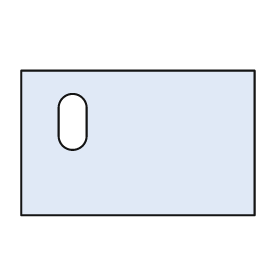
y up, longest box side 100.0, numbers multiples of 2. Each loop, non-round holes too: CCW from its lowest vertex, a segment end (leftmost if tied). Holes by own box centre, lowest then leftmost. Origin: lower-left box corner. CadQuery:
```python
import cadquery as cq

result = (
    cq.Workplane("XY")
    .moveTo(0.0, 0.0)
    .lineTo(100.0, 0.0)
    .lineTo(100.0, 62.0)
    .lineTo(0.0, 62.0)
    .close()
    .moveTo(16.0, 34.0)
    .threePointArc((22.0, 28.0), (28.0, 34.0))
    .lineTo(28.0, 46.0)
    .threePointArc((22.0, 52.0), (16.0, 46.0))
    .close()
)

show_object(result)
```